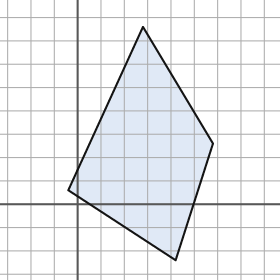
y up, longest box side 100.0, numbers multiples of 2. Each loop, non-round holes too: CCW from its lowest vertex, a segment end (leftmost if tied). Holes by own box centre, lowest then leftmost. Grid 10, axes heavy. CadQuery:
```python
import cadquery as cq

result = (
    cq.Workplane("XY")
    .moveTo(42.0, -24.0)
    .lineTo(58.0, 26.0)
    .lineTo(28.0, 76.0)
    .lineTo(-4.0, 6.0)
    .close()
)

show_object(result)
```